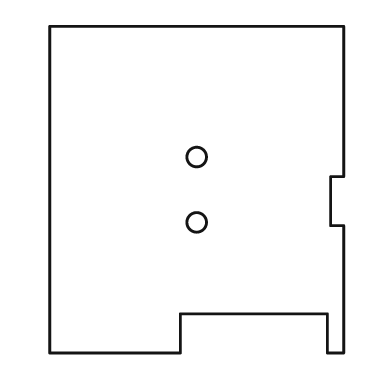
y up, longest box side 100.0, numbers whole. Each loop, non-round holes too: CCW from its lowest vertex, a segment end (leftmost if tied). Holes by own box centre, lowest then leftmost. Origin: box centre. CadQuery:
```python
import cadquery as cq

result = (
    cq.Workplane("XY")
    .moveTo(-45.0, -50.0)
    .lineTo(-5.0, -50.0)
    .lineTo(-5.0, -38.0)
    .lineTo(40.0, -38.0)
    .lineTo(40.0, -50.0)
    .lineTo(45.0, -50.0)
    .lineTo(45.0, -11.0)
    .lineTo(41.0, -11.0)
    .lineTo(41.0, 4.0)
    .lineTo(45.0, 4.0)
    .lineTo(45.0, 50.0)
    .lineTo(-45.0, 50.0)
    .close()
    .moveTo(0.0, -10.0)
    .circle(3.0)
    .moveTo(0.0, 10.0)
    .circle(3.0)
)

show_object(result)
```